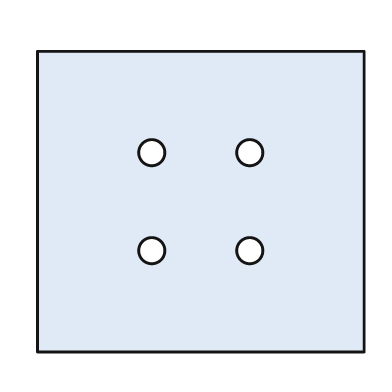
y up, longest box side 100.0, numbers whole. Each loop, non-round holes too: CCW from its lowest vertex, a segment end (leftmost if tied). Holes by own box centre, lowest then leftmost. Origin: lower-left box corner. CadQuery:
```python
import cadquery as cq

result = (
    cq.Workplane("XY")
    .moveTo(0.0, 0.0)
    .lineTo(100.0, 0.0)
    .lineTo(100.0, 92.0)
    .lineTo(0.0, 92.0)
    .close()
    .moveTo(35.0, 31.0)
    .circle(4.0)
    .moveTo(65.0, 31.0)
    .circle(4.0)
    .moveTo(35.0, 61.0)
    .circle(4.0)
    .moveTo(65.0, 61.0)
    .circle(4.0)
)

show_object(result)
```